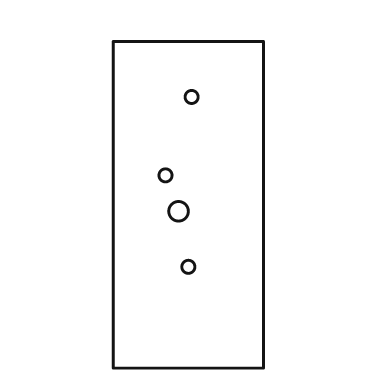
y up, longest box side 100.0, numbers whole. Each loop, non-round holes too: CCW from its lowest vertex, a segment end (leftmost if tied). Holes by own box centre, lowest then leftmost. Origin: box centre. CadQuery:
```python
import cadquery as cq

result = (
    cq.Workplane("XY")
    .moveTo(-23.0, -50.0)
    .lineTo(23.0, -50.0)
    .lineTo(23.0, 50.0)
    .lineTo(-23.0, 50.0)
    .close()
    .moveTo(0.0, -19.0)
    .circle(2.0)
    .moveTo(-3.0, -2.0)
    .circle(3.0)
    .moveTo(-7.0, 9.0)
    .circle(2.0)
    .moveTo(1.0, 33.0)
    .circle(2.0)
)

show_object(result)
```